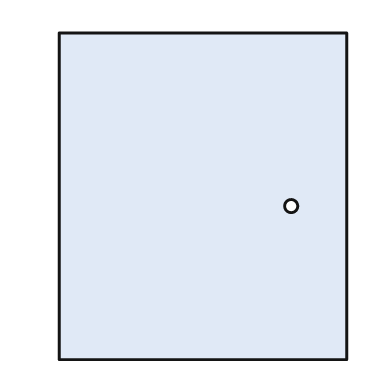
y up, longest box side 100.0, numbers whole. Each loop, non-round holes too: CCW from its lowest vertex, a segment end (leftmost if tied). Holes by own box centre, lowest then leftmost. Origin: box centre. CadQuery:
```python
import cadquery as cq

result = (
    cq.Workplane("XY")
    .moveTo(-44.0, -50.0)
    .lineTo(44.0, -50.0)
    .lineTo(44.0, 50.0)
    .lineTo(-44.0, 50.0)
    .close()
    .moveTo(27.0, -3.0)
    .circle(2.0)
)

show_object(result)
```